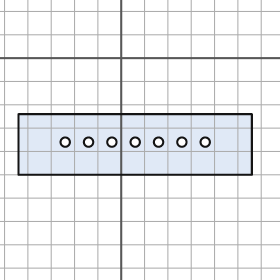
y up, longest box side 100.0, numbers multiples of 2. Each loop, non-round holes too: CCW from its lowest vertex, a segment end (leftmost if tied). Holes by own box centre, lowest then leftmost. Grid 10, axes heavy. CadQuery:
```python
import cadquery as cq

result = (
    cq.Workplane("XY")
    .moveTo(-44.0, -50.0)
    .lineTo(56.0, -50.0)
    .lineTo(56.0, -24.0)
    .lineTo(-44.0, -24.0)
    .close()
    .moveTo(-24.0, -36.0)
    .circle(2.0)
    .moveTo(-14.0, -36.0)
    .circle(2.0)
    .moveTo(-4.0, -36.0)
    .circle(2.0)
    .moveTo(6.0, -36.0)
    .circle(2.0)
    .moveTo(16.0, -36.0)
    .circle(2.0)
    .moveTo(26.0, -36.0)
    .circle(2.0)
    .moveTo(36.0, -36.0)
    .circle(2.0)
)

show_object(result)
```